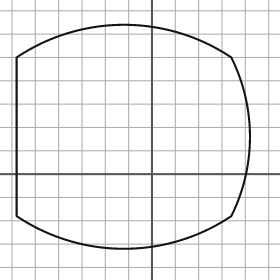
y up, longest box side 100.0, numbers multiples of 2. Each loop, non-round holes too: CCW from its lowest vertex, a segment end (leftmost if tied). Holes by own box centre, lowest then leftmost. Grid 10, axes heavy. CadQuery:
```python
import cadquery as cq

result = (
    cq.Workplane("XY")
    .moveTo(-58.0, -18.0)
    .threePointArc((-12.0, -32.0), (34.0, -18.0))
    .threePointArc((42.0, 16.0), (34.0, 50.0))
    .threePointArc((-12.0, 64.0), (-58.0, 50.0))
    .close()
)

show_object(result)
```